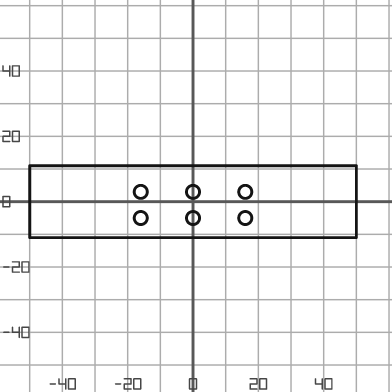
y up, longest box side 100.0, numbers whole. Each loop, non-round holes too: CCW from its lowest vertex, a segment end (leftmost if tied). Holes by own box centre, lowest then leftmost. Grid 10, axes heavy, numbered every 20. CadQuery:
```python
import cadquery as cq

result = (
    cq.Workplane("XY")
    .moveTo(-50.0, -11.0)
    .lineTo(50.0, -11.0)
    .lineTo(50.0, 11.0)
    .lineTo(-50.0, 11.0)
    .close()
    .moveTo(-16.0, -5.0)
    .circle(2.0)
    .moveTo(0.0, -5.0)
    .circle(2.0)
    .moveTo(16.0, -5.0)
    .circle(2.0)
    .moveTo(-16.0, 3.0)
    .circle(2.0)
    .moveTo(0.0, 3.0)
    .circle(2.0)
    .moveTo(16.0, 3.0)
    .circle(2.0)
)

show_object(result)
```